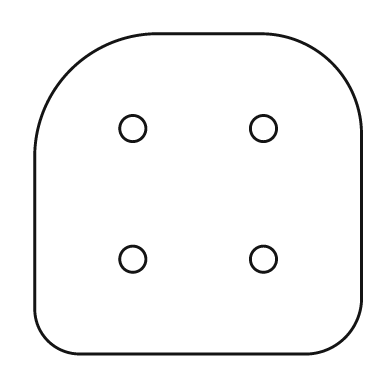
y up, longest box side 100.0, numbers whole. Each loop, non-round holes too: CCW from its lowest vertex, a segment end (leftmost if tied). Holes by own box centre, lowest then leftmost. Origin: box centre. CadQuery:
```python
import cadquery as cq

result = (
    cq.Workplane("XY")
    .moveTo(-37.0, -49.0)
    .lineTo(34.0, -49.0)
    .threePointArc((45.0, -44.0), (50.0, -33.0))
    .lineTo(50.0, 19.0)
    .threePointArc((41.0, 40.0), (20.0, 49.0))
    .lineTo(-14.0, 49.0)
    .threePointArc((-39.0, 38.0), (-50.0, 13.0))
    .lineTo(-50.0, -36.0)
    .threePointArc((-46.0, -45.0), (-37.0, -49.0))
    .close()
    .moveTo(-20.0, -20.0)
    .circle(4.0)
    .moveTo(20.0, -20.0)
    .circle(4.0)
    .moveTo(-20.0, 20.0)
    .circle(4.0)
    .moveTo(20.0, 20.0)
    .circle(4.0)
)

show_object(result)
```